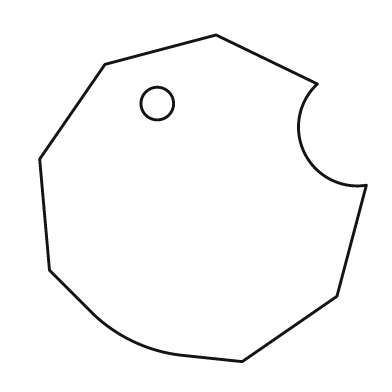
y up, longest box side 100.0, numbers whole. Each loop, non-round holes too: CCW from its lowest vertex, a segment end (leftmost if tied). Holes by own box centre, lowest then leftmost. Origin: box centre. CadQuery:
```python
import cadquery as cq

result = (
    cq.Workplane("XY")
    .moveTo(12.0, -50.0)
    .lineTo(41.0, -30.0)
    .lineTo(50.0, 4.0)
    .threePointArc((31.0, 14.0), (35.0, 35.0))
    .lineTo(4.0, 50.0)
    .lineTo(-30.0, 41.0)
    .lineTo(-50.0, 12.0)
    .lineTo(-47.0, -22.0)
    .lineTo(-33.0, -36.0)
    .threePointArc((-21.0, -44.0), (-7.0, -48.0))
    .close()
    .moveTo(-14.0, 29.0)
    .circle(5.0)
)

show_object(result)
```